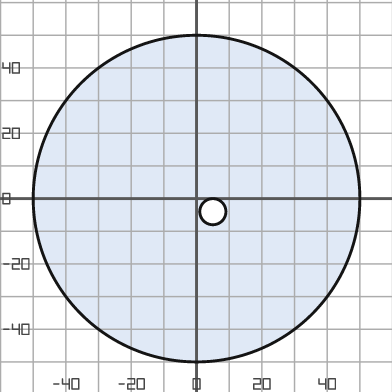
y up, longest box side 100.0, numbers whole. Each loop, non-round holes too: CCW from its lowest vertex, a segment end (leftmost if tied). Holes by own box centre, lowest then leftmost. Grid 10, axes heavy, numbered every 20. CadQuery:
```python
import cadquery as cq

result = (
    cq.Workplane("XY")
    .moveTo(0.0, 0.0)
    .circle(50.0)
    .moveTo(5.0, -4.0)
    .circle(4.0)
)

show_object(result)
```